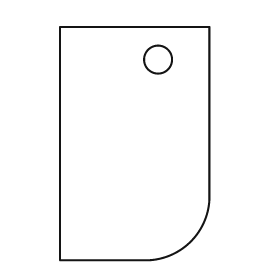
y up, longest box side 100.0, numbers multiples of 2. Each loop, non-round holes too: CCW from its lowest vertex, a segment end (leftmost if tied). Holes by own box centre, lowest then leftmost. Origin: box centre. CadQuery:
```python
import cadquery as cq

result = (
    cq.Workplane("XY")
    .moveTo(-32.0, -50.0)
    .lineTo(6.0, -50.0)
    .threePointArc((24.0, -42.0), (32.0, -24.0))
    .lineTo(32.0, 50.0)
    .lineTo(-32.0, 50.0)
    .close()
    .moveTo(10.0, 36.0)
    .circle(6.0)
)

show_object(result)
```